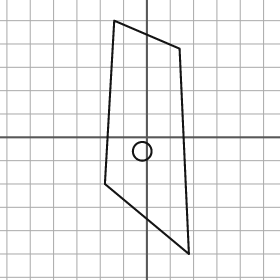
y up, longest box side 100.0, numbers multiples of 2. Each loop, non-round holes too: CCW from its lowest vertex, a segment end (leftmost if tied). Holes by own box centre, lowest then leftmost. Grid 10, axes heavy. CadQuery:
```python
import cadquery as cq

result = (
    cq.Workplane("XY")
    .moveTo(18.0, -50.0)
    .lineTo(14.0, 38.0)
    .lineTo(-14.0, 50.0)
    .lineTo(-18.0, -20.0)
    .close()
    .moveTo(-2.0, -6.0)
    .circle(4.0)
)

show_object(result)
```